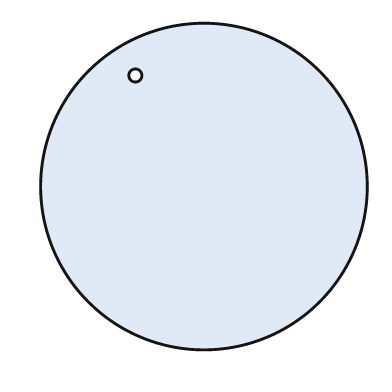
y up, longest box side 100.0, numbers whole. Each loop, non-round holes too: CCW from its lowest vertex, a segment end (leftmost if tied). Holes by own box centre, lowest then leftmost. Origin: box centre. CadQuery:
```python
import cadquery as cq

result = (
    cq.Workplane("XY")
    .moveTo(0.0, 0.0)
    .circle(50.0)
    .moveTo(-21.0, 34.0)
    .circle(2.0)
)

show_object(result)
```